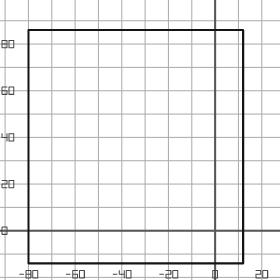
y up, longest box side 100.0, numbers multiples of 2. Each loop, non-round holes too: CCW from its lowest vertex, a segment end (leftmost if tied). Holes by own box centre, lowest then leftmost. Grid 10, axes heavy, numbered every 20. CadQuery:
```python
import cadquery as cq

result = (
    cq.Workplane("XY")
    .moveTo(-80.0, -14.0)
    .lineTo(12.0, -14.0)
    .lineTo(12.0, 86.0)
    .lineTo(-80.0, 86.0)
    .close()
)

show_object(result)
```